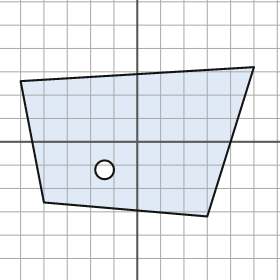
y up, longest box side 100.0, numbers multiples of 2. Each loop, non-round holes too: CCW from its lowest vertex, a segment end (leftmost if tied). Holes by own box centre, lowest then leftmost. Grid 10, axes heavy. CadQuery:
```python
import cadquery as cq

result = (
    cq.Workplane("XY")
    .moveTo(30.0, -32.0)
    .lineTo(50.0, 32.0)
    .lineTo(-50.0, 26.0)
    .lineTo(-40.0, -26.0)
    .close()
    .moveTo(-14.0, -12.0)
    .circle(4.0)
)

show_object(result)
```